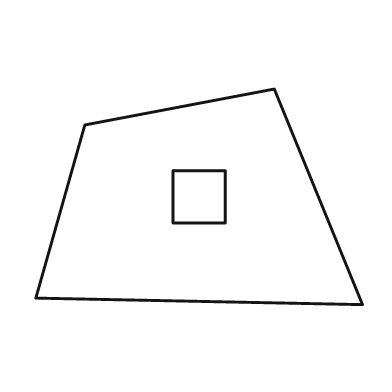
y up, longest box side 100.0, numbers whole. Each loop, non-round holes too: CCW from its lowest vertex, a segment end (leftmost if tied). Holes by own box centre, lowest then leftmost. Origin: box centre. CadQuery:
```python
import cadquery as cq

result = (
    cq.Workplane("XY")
    .moveTo(50.0, -33.0)
    .lineTo(23.0, 33.0)
    .lineTo(-35.0, 22.0)
    .lineTo(-50.0, -31.0)
    .close()
    .moveTo(-8.0, -8.0)
    .lineTo(8.0, -8.0)
    .lineTo(8.0, 8.0)
    .lineTo(-8.0, 8.0)
    .close()
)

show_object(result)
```